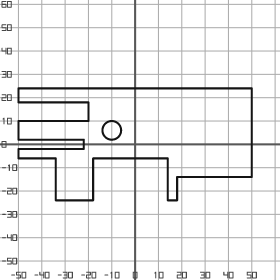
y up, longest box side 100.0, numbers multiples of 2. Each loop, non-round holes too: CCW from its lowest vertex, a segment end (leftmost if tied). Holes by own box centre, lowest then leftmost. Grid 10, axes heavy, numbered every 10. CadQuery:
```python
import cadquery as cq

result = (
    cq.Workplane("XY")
    .moveTo(-34.0, -24.0)
    .lineTo(-18.0, -24.0)
    .lineTo(-18.0, -6.0)
    .lineTo(14.0, -6.0)
    .lineTo(14.0, -24.0)
    .lineTo(18.0, -24.0)
    .lineTo(18.0, -14.0)
    .lineTo(50.0, -14.0)
    .lineTo(50.0, 24.0)
    .lineTo(-50.0, 24.0)
    .lineTo(-50.0, 18.0)
    .lineTo(-20.0, 18.0)
    .lineTo(-20.0, 10.0)
    .lineTo(-50.0, 10.0)
    .lineTo(-50.0, 2.0)
    .lineTo(-22.0, 2.0)
    .lineTo(-22.0, -2.0)
    .lineTo(-50.0, -2.0)
    .lineTo(-50.0, -6.0)
    .lineTo(-34.0, -6.0)
    .close()
    .moveTo(-10.0, 6.0)
    .circle(4.0)
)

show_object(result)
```